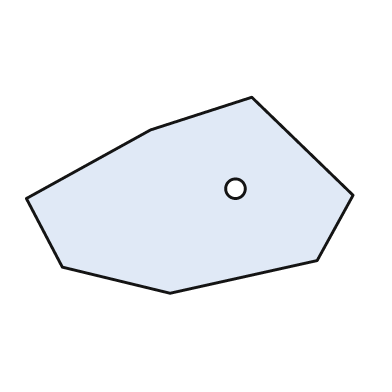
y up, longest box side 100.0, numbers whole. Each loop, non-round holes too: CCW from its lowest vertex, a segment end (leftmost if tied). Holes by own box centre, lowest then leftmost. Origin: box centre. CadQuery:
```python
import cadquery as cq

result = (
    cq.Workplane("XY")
    .moveTo(-6.0, -30.0)
    .lineTo(39.0, -20.0)
    .lineTo(50.0, 0.0)
    .lineTo(19.0, 30.0)
    .lineTo(-12.0, 20.0)
    .lineTo(-50.0, -1.0)
    .lineTo(-39.0, -22.0)
    .close()
    .moveTo(14.0, 2.0)
    .circle(3.0)
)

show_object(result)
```